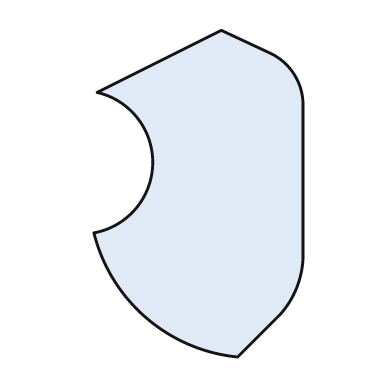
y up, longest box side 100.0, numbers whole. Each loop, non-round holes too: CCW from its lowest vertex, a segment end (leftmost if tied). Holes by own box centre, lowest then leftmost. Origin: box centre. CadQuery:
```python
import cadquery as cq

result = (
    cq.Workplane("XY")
    .moveTo(12.0, -50.0)
    .lineTo(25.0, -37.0)
    .threePointArc((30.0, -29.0), (32.0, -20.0))
    .lineTo(32.0, 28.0)
    .threePointArc((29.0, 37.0), (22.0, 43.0))
    .lineTo(7.0, 50.0)
    .lineTo(-31.0, 31.0)
    .threePointArc((-14.0, 9.0), (-32.0, -12.0))
    .threePointArc((-16.0, -38.0), (12.0, -50.0))
    .close()
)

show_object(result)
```